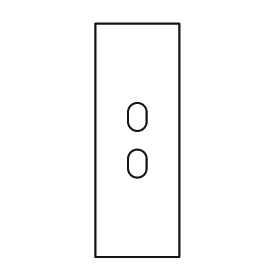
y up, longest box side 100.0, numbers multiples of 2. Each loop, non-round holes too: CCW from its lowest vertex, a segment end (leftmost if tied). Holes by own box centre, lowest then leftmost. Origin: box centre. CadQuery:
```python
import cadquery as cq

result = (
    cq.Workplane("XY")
    .moveTo(-18.0, -50.0)
    .lineTo(18.0, -50.0)
    .lineTo(18.0, 50.0)
    .lineTo(-18.0, 50.0)
    .close()
    .moveTo(-4.0, -12.0)
    .threePointArc((0.0, -16.0), (4.0, -12.0))
    .lineTo(4.0, -8.0)
    .threePointArc((0.0, -4.0), (-4.0, -8.0))
    .close()
    .moveTo(-4.0, 8.0)
    .threePointArc((0.0, 4.0), (4.0, 8.0))
    .lineTo(4.0, 12.0)
    .threePointArc((0.0, 16.0), (-4.0, 12.0))
    .close()
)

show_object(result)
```